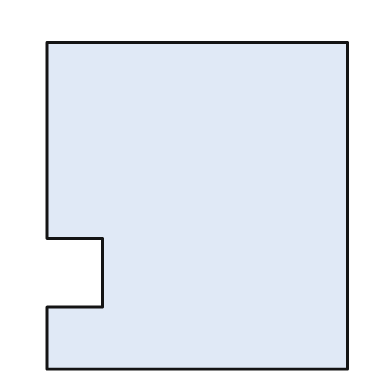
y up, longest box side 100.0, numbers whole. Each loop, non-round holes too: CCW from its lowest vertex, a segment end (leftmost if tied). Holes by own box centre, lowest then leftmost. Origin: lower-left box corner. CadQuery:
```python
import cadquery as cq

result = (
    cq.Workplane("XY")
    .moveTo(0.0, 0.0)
    .lineTo(92.0, 0.0)
    .lineTo(92.0, 100.0)
    .lineTo(0.0, 100.0)
    .lineTo(0.0, 40.0)
    .lineTo(17.0, 40.0)
    .lineTo(17.0, 19.0)
    .lineTo(0.0, 19.0)
    .close()
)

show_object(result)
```